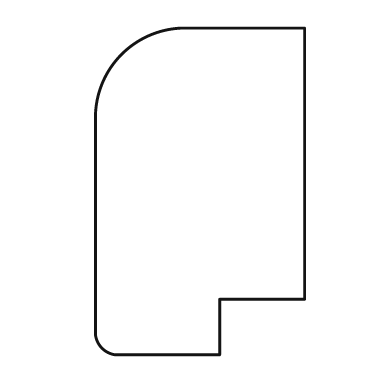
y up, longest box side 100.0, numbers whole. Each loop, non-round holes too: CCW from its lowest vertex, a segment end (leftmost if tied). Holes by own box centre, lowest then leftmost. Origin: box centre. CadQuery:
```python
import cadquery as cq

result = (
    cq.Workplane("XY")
    .moveTo(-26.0, -50.0)
    .lineTo(6.0, -50.0)
    .lineTo(6.0, -33.0)
    .lineTo(32.0, -33.0)
    .lineTo(32.0, 50.0)
    .lineTo(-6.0, 50.0)
    .threePointArc((-24.0, 42.0), (-32.0, 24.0))
    .lineTo(-32.0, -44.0)
    .threePointArc((-30.0, -48.0), (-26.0, -50.0))
    .close()
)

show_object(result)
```